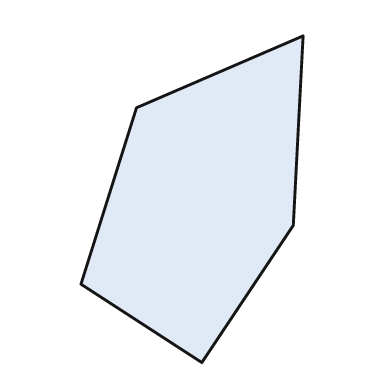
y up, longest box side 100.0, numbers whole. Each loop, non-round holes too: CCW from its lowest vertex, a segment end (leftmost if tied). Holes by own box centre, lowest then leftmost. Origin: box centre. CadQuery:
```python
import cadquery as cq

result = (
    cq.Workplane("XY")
    .moveTo(3.0, -50.0)
    .lineTo(31.0, -8.0)
    .lineTo(34.0, 50.0)
    .lineTo(-17.0, 28.0)
    .lineTo(-34.0, -26.0)
    .close()
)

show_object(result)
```